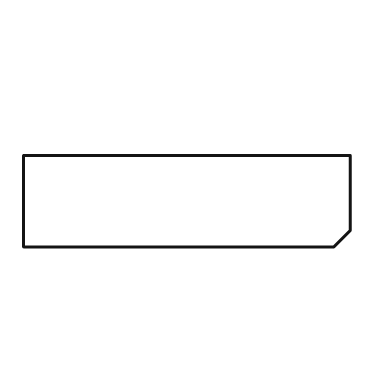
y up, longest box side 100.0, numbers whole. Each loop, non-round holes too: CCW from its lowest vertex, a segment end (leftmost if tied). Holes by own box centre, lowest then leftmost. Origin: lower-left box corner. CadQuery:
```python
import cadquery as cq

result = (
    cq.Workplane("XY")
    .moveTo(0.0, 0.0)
    .lineTo(95.0, 0.0)
    .lineTo(100.0, 5.0)
    .lineTo(100.0, 28.0)
    .lineTo(0.0, 28.0)
    .close()
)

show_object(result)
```